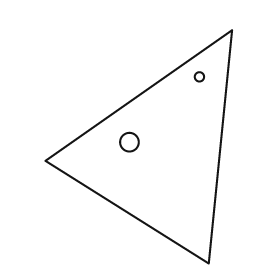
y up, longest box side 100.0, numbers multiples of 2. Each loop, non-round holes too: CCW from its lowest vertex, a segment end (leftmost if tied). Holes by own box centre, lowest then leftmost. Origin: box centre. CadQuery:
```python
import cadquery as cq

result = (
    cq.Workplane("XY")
    .moveTo(30.0, -50.0)
    .lineTo(40.0, 50.0)
    .lineTo(-40.0, -6.0)
    .close()
    .moveTo(-4.0, 2.0)
    .circle(4.0)
    .moveTo(26.0, 30.0)
    .circle(2.0)
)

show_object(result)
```